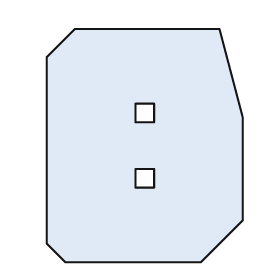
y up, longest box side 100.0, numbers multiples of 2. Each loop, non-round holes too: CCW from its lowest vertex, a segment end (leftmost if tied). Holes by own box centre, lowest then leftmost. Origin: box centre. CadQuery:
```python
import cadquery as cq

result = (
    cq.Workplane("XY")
    .moveTo(-34.0, -50.0)
    .lineTo(24.0, -50.0)
    .lineTo(42.0, -32.0)
    .lineTo(42.0, 12.0)
    .lineTo(32.0, 50.0)
    .lineTo(-30.0, 50.0)
    .lineTo(-42.0, 38.0)
    .lineTo(-42.0, -42.0)
    .close()
    .moveTo(-4.0, -18.0)
    .lineTo(4.0, -18.0)
    .lineTo(4.0, -10.0)
    .lineTo(-4.0, -10.0)
    .close()
    .moveTo(-4.0, 10.0)
    .lineTo(4.0, 10.0)
    .lineTo(4.0, 18.0)
    .lineTo(-4.0, 18.0)
    .close()
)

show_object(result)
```